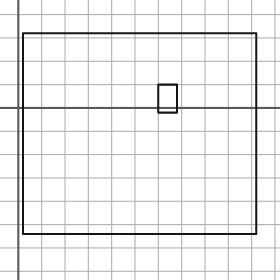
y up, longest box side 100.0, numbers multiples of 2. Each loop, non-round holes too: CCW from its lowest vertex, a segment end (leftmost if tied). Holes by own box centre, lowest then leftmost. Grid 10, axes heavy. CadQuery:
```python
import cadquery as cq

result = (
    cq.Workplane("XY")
    .moveTo(2.0, -54.0)
    .lineTo(102.0, -54.0)
    .lineTo(102.0, 32.0)
    .lineTo(2.0, 32.0)
    .close()
    .moveTo(60.0, -2.0)
    .lineTo(68.0, -2.0)
    .lineTo(68.0, 10.0)
    .lineTo(60.0, 10.0)
    .close()
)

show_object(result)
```